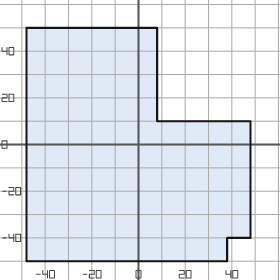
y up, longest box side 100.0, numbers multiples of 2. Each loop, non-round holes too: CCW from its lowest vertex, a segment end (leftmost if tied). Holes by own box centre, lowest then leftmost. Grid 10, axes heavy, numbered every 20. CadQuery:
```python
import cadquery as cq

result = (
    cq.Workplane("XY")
    .moveTo(-48.0, -50.0)
    .lineTo(38.0, -50.0)
    .lineTo(38.0, -40.0)
    .lineTo(48.0, -40.0)
    .lineTo(48.0, 10.0)
    .lineTo(8.0, 10.0)
    .lineTo(8.0, 50.0)
    .lineTo(-48.0, 50.0)
    .close()
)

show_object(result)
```